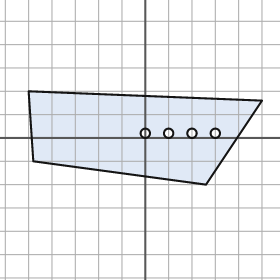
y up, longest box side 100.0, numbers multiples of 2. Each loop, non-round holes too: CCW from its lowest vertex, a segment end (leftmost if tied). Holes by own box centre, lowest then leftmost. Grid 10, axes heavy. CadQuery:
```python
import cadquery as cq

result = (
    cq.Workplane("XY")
    .moveTo(26.0, -20.0)
    .lineTo(50.0, 16.0)
    .lineTo(-50.0, 20.0)
    .lineTo(-48.0, -10.0)
    .close()
    .moveTo(0.0, 2.0)
    .circle(2.0)
    .moveTo(10.0, 2.0)
    .circle(2.0)
    .moveTo(20.0, 2.0)
    .circle(2.0)
    .moveTo(30.0, 2.0)
    .circle(2.0)
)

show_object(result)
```